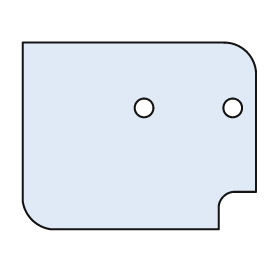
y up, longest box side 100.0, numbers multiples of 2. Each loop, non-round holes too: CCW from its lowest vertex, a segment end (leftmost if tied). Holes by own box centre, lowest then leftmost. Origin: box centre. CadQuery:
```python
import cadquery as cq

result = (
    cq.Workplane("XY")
    .moveTo(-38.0, -40.0)
    .lineTo(34.0, -40.0)
    .lineTo(34.0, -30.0)
    .threePointArc((36.0, -26.0), (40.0, -24.0))
    .lineTo(50.0, -24.0)
    .lineTo(50.0, 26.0)
    .threePointArc((46.0, 36.0), (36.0, 40.0))
    .lineTo(-50.0, 40.0)
    .lineTo(-50.0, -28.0)
    .threePointArc((-46.0, -36.0), (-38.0, -40.0))
    .close()
    .moveTo(2.0, 12.0)
    .circle(4.0)
    .moveTo(40.0, 12.0)
    .circle(4.0)
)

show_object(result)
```